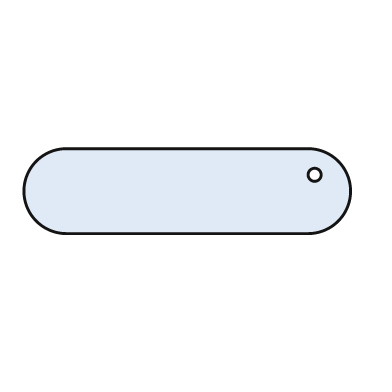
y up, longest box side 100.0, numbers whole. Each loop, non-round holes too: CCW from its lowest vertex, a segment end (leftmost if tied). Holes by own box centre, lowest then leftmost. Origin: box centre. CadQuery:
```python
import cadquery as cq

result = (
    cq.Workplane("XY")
    .moveTo(-37.0, -13.0)
    .lineTo(37.0, -13.0)
    .threePointArc((50.0, 0.0), (37.0, 13.0))
    .lineTo(-37.0, 13.0)
    .threePointArc((-50.0, 0.0), (-37.0, -13.0))
    .close()
    .moveTo(39.0, 5.0)
    .circle(2.0)
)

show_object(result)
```